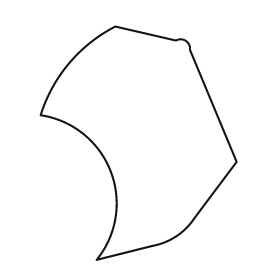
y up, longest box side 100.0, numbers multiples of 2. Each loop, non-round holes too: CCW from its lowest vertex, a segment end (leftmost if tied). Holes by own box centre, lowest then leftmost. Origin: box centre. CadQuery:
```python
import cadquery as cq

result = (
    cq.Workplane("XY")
    .moveTo(-18.0, -50.0)
    .lineTo(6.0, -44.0)
    .threePointArc((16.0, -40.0), (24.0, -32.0))
    .lineTo(42.0, -8.0)
    .lineTo(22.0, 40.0)
    .threePointArc((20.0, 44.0), (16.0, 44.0))
    .lineTo(-10.0, 50.0)
    .threePointArc((-30.0, 34.0), (-42.0, 12.0))
    .threePointArc((-12.0, -12.0), (-18.0, -50.0))
    .close()
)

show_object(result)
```